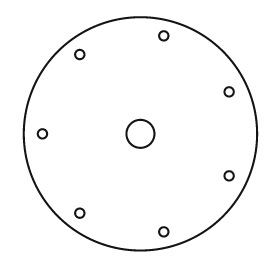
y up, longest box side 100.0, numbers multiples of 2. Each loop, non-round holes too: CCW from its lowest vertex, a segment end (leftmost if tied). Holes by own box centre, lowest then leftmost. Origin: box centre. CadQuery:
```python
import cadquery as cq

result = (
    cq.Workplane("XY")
    .moveTo(0.0, 0.0)
    .circle(50.0)
    .moveTo(10.0, -42.0)
    .circle(2.0)
    .moveTo(-26.0, -34.0)
    .circle(2.0)
    .moveTo(38.0, -18.0)
    .circle(2.0)
    .moveTo(-42.0, 0.0)
    .circle(2.0)
    .moveTo(0.0, 0.0)
    .circle(6.0)
    .moveTo(38.0, 18.0)
    .circle(2.0)
    .moveTo(-26.0, 34.0)
    .circle(2.0)
    .moveTo(10.0, 42.0)
    .circle(2.0)
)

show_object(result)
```